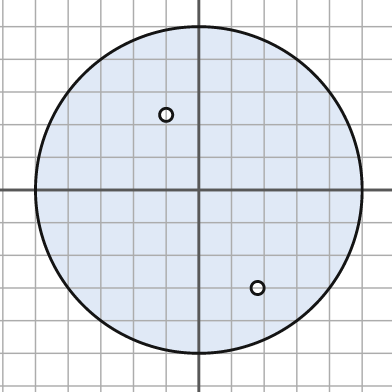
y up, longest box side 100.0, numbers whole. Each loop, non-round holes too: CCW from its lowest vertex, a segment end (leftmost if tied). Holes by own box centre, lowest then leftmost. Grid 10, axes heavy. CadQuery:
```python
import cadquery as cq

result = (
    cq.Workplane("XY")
    .moveTo(0.0, 0.0)
    .circle(50.0)
    .moveTo(18.0, -30.0)
    .circle(2.0)
    .moveTo(-10.0, 23.0)
    .circle(2.0)
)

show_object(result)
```